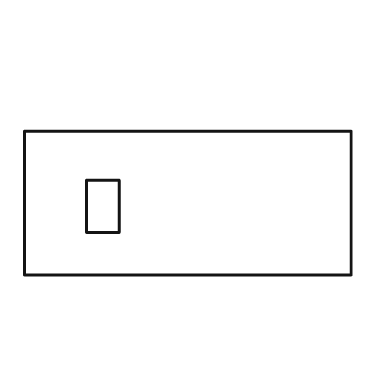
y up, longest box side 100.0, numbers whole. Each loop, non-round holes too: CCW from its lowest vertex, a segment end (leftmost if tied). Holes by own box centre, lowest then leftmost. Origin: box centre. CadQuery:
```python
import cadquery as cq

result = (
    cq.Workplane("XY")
    .moveTo(-50.0, -22.0)
    .lineTo(50.0, -22.0)
    .lineTo(50.0, 22.0)
    .lineTo(-50.0, 22.0)
    .close()
    .moveTo(-31.0, -9.0)
    .lineTo(-21.0, -9.0)
    .lineTo(-21.0, 7.0)
    .lineTo(-31.0, 7.0)
    .close()
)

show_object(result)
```